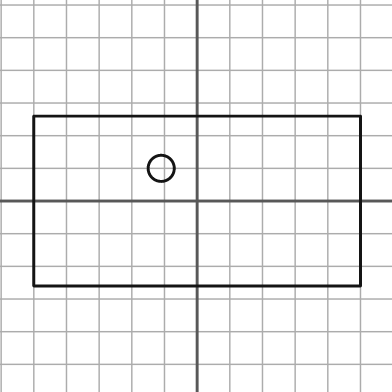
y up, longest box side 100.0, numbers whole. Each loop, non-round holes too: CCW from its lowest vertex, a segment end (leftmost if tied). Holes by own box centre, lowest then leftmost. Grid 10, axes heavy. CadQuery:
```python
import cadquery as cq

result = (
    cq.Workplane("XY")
    .moveTo(-50.0, -26.0)
    .lineTo(50.0, -26.0)
    .lineTo(50.0, 26.0)
    .lineTo(-50.0, 26.0)
    .close()
    .moveTo(-11.0, 10.0)
    .circle(4.0)
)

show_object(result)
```